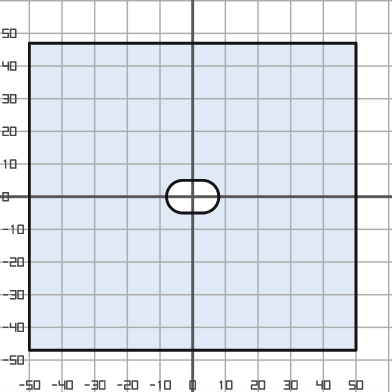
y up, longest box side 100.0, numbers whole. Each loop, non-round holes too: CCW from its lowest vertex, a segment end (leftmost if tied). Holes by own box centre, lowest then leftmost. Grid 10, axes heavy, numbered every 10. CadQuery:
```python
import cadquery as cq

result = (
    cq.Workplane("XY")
    .moveTo(-50.0, -47.0)
    .lineTo(50.0, -47.0)
    .lineTo(50.0, 47.0)
    .lineTo(-50.0, 47.0)
    .close()
    .moveTo(-3.0, -5.0)
    .lineTo(3.0, -5.0)
    .threePointArc((8.0, 0.0), (3.0, 5.0))
    .lineTo(-3.0, 5.0)
    .threePointArc((-8.0, 0.0), (-3.0, -5.0))
    .close()
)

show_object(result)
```